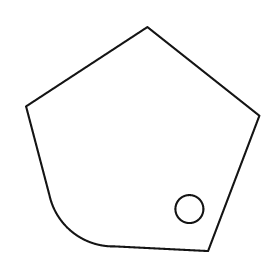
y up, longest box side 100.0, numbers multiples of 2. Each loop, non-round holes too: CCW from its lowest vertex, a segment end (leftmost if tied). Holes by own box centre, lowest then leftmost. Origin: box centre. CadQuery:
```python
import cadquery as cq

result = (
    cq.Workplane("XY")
    .moveTo(28.0, -48.0)
    .lineTo(50.0, 10.0)
    .lineTo(2.0, 48.0)
    .lineTo(-50.0, 14.0)
    .lineTo(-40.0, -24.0)
    .threePointArc((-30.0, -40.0), (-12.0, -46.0))
    .close()
    .moveTo(20.0, -30.0)
    .circle(6.0)
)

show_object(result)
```